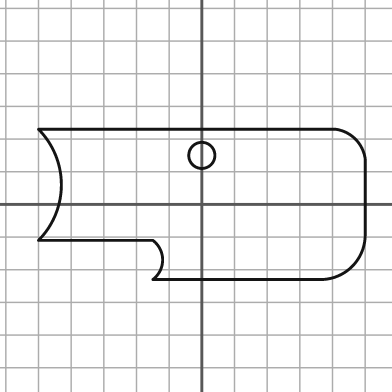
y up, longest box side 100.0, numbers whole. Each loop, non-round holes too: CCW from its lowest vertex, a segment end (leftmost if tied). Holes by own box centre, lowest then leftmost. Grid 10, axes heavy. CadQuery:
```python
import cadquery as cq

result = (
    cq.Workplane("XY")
    .moveTo(-15.0, -23.0)
    .lineTo(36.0, -23.0)
    .threePointArc((46.0, -19.0), (50.0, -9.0))
    .lineTo(50.0, 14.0)
    .threePointArc((47.0, 20.0), (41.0, 23.0))
    .lineTo(-50.0, 23.0)
    .threePointArc((-43.0, 6.0), (-50.0, -11.0))
    .lineTo(-15.0, -11.0)
    .threePointArc((-12.0, -17.0), (-15.0, -23.0))
    .close()
    .moveTo(0.0, 15.0)
    .circle(4.0)
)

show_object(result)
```